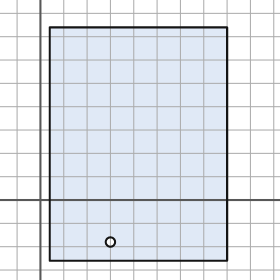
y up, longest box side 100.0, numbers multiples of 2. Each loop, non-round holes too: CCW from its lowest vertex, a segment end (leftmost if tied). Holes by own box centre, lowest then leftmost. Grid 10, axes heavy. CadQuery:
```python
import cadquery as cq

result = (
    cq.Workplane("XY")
    .moveTo(4.0, -26.0)
    .lineTo(80.0, -26.0)
    .lineTo(80.0, 74.0)
    .lineTo(4.0, 74.0)
    .close()
    .moveTo(30.0, -18.0)
    .circle(2.0)
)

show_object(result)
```